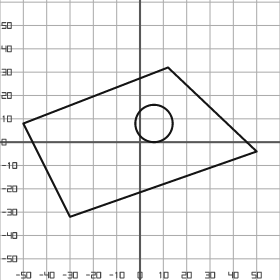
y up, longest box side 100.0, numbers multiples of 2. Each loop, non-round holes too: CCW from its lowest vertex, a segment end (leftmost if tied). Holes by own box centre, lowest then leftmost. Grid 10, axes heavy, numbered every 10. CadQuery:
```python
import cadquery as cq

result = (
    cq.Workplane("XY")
    .moveTo(-30.0, -32.0)
    .lineTo(50.0, -4.0)
    .lineTo(12.0, 32.0)
    .lineTo(-50.0, 8.0)
    .close()
    .moveTo(6.0, 8.0)
    .circle(8.0)
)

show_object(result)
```